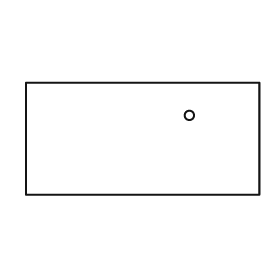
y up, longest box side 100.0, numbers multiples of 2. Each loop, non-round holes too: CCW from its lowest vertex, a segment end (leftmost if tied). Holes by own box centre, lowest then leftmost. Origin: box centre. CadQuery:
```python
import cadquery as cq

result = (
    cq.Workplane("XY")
    .moveTo(-50.0, -24.0)
    .lineTo(50.0, -24.0)
    .lineTo(50.0, 24.0)
    .lineTo(-50.0, 24.0)
    .close()
    .moveTo(20.0, 10.0)
    .circle(2.0)
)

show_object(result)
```